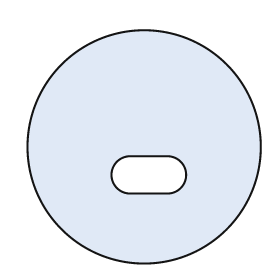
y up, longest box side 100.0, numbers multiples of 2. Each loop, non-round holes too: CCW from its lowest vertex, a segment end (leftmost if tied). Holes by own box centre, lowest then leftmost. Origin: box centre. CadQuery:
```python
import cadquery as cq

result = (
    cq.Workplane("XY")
    .moveTo(0.0, 0.0)
    .circle(50.0)
    .moveTo(-6.0, -20.0)
    .lineTo(10.0, -20.0)
    .threePointArc((18.0, -12.0), (10.0, -4.0))
    .lineTo(-6.0, -4.0)
    .threePointArc((-14.0, -12.0), (-6.0, -20.0))
    .close()
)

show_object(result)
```